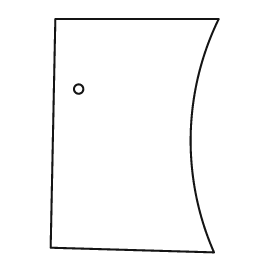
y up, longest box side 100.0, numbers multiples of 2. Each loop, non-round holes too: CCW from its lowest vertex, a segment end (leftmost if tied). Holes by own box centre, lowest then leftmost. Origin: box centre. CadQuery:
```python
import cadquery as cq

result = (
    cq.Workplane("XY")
    .moveTo(34.0, -50.0)
    .threePointArc((24.0, 0.0), (36.0, 50.0))
    .lineTo(-34.0, 50.0)
    .lineTo(-36.0, -48.0)
    .close()
    .moveTo(-24.0, 20.0)
    .circle(2.0)
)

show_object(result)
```